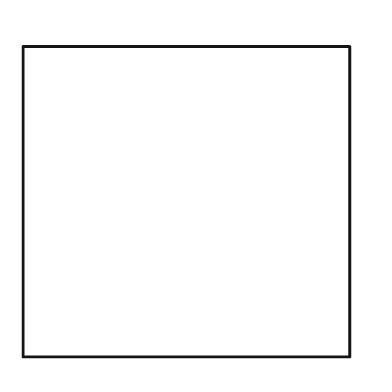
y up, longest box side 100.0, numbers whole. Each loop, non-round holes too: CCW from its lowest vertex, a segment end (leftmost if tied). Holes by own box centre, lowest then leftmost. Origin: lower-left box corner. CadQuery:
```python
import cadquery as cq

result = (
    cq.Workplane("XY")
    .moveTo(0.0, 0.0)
    .lineTo(100.0, 0.0)
    .lineTo(100.0, 95.0)
    .lineTo(0.0, 95.0)
    .close()
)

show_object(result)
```